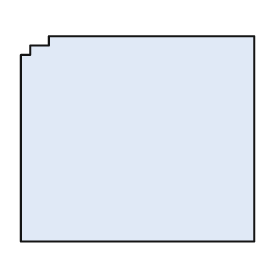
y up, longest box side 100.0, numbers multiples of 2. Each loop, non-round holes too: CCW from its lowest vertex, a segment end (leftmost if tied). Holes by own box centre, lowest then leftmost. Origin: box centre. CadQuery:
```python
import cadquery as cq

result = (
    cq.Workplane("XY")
    .moveTo(-50.0, -44.0)
    .lineTo(50.0, -44.0)
    .lineTo(50.0, 44.0)
    .lineTo(-38.0, 44.0)
    .lineTo(-38.0, 40.0)
    .lineTo(-46.0, 40.0)
    .lineTo(-46.0, 36.0)
    .lineTo(-50.0, 36.0)
    .close()
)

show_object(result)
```